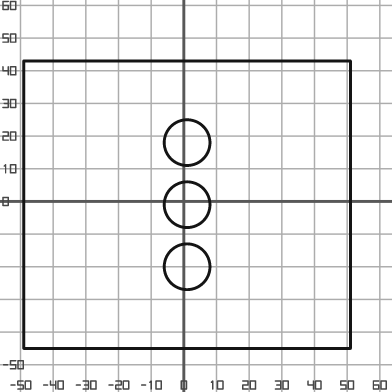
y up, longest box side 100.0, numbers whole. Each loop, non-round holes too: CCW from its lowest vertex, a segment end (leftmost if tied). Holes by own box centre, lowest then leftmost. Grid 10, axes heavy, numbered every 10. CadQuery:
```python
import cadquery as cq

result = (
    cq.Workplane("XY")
    .moveTo(-49.0, -45.0)
    .lineTo(51.0, -45.0)
    .lineTo(51.0, 43.0)
    .lineTo(-49.0, 43.0)
    .close()
    .moveTo(1.0, -20.0)
    .circle(7.0)
    .moveTo(1.0, -1.0)
    .circle(7.0)
    .moveTo(1.0, 18.0)
    .circle(7.0)
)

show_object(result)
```